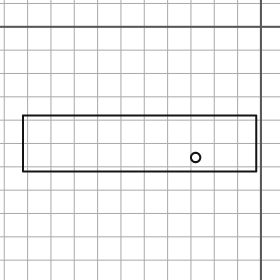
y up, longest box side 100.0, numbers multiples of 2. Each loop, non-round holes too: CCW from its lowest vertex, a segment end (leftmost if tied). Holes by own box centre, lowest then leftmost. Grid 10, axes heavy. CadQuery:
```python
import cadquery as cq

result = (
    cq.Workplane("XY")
    .moveTo(-102.0, -62.0)
    .lineTo(-2.0, -62.0)
    .lineTo(-2.0, -38.0)
    .lineTo(-102.0, -38.0)
    .close()
    .moveTo(-28.0, -56.0)
    .circle(2.0)
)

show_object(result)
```